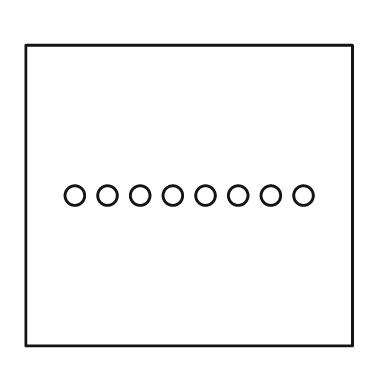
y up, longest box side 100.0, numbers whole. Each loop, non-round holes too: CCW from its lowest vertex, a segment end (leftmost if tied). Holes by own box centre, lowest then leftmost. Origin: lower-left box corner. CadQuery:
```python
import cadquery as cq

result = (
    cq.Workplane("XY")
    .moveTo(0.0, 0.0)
    .lineTo(100.0, 0.0)
    .lineTo(100.0, 92.0)
    .lineTo(0.0, 92.0)
    .close()
    .moveTo(15.0, 46.0)
    .circle(3.0)
    .moveTo(25.0, 46.0)
    .circle(3.0)
    .moveTo(35.0, 46.0)
    .circle(3.0)
    .moveTo(45.0, 46.0)
    .circle(3.0)
    .moveTo(55.0, 46.0)
    .circle(3.0)
    .moveTo(65.0, 46.0)
    .circle(3.0)
    .moveTo(75.0, 46.0)
    .circle(3.0)
    .moveTo(85.0, 46.0)
    .circle(3.0)
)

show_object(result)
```